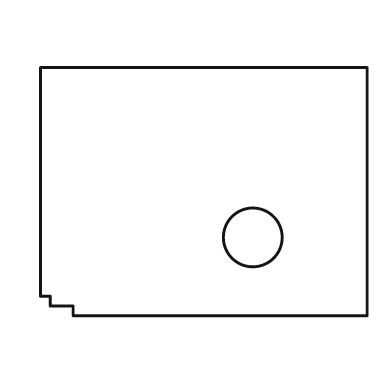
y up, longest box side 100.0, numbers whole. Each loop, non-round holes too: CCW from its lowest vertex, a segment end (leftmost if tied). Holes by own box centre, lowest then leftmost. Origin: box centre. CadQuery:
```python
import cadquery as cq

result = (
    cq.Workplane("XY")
    .moveTo(-40.0, -38.0)
    .lineTo(50.0, -38.0)
    .lineTo(50.0, 38.0)
    .lineTo(-50.0, 38.0)
    .lineTo(-50.0, -32.0)
    .lineTo(-47.0, -32.0)
    .lineTo(-47.0, -35.0)
    .lineTo(-40.0, -35.0)
    .close()
    .moveTo(15.0, -14.0)
    .circle(9.0)
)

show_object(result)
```